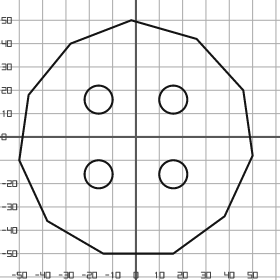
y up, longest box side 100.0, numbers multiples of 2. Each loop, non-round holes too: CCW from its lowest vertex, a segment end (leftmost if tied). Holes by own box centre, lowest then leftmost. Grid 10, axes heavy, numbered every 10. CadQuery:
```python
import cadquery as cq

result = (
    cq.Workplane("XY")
    .moveTo(-14.0, -50.0)
    .lineTo(16.0, -50.0)
    .lineTo(38.0, -34.0)
    .lineTo(50.0, -8.0)
    .lineTo(46.0, 20.0)
    .lineTo(26.0, 42.0)
    .lineTo(-2.0, 50.0)
    .lineTo(-28.0, 40.0)
    .lineTo(-46.0, 18.0)
    .lineTo(-50.0, -10.0)
    .lineTo(-38.0, -36.0)
    .close()
    .moveTo(-16.0, -16.0)
    .circle(6.0)
    .moveTo(16.0, -16.0)
    .circle(6.0)
    .moveTo(-16.0, 16.0)
    .circle(6.0)
    .moveTo(16.0, 16.0)
    .circle(6.0)
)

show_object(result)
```